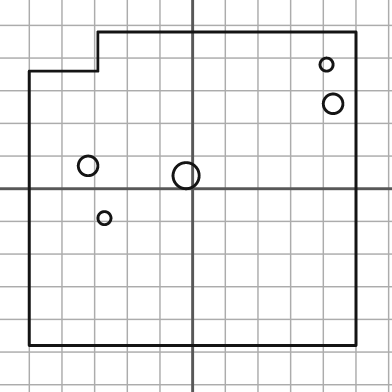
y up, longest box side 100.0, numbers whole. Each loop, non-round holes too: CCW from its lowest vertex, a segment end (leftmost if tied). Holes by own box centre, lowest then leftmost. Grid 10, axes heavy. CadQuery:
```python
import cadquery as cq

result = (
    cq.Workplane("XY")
    .moveTo(-50.0, -48.0)
    .lineTo(50.0, -48.0)
    .lineTo(50.0, 48.0)
    .lineTo(-29.0, 48.0)
    .lineTo(-29.0, 36.0)
    .lineTo(-50.0, 36.0)
    .close()
    .moveTo(-27.0, -9.0)
    .circle(2.0)
    .moveTo(-2.0, 4.0)
    .circle(4.0)
    .moveTo(-32.0, 7.0)
    .circle(3.0)
    .moveTo(43.0, 26.0)
    .circle(3.0)
    .moveTo(41.0, 38.0)
    .circle(2.0)
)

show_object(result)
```